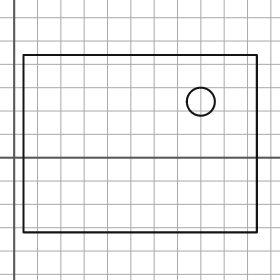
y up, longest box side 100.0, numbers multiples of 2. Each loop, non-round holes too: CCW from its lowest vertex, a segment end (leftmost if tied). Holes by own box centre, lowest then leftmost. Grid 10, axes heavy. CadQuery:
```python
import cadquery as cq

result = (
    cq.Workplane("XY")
    .moveTo(4.0, -32.0)
    .lineTo(104.0, -32.0)
    .lineTo(104.0, 44.0)
    .lineTo(4.0, 44.0)
    .close()
    .moveTo(80.0, 24.0)
    .circle(6.0)
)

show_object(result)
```